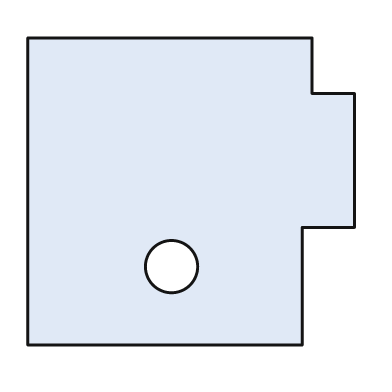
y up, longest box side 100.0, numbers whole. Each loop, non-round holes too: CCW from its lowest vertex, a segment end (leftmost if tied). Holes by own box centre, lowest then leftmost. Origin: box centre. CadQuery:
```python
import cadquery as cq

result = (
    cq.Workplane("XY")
    .moveTo(-50.0, -47.0)
    .lineTo(34.0, -47.0)
    .lineTo(34.0, -11.0)
    .lineTo(50.0, -11.0)
    .lineTo(50.0, 30.0)
    .lineTo(37.0, 30.0)
    .lineTo(37.0, 47.0)
    .lineTo(-50.0, 47.0)
    .close()
    .moveTo(-6.0, -23.0)
    .circle(8.0)
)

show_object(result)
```